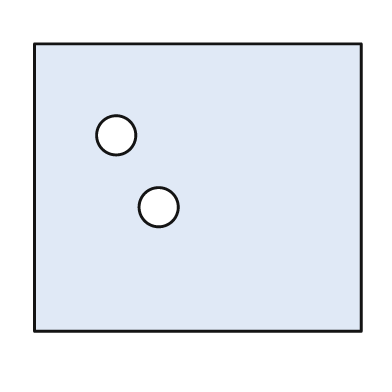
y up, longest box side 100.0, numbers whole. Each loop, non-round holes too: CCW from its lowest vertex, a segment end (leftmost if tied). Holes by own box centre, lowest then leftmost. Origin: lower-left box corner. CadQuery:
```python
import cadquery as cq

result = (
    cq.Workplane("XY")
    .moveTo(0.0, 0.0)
    .lineTo(100.0, 0.0)
    .lineTo(100.0, 88.0)
    .lineTo(0.0, 88.0)
    .close()
    .moveTo(38.0, 38.0)
    .circle(6.0)
    .moveTo(25.0, 60.0)
    .circle(6.0)
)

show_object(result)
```